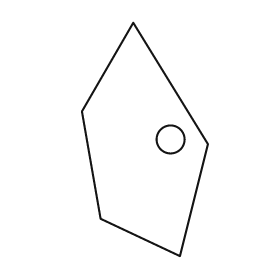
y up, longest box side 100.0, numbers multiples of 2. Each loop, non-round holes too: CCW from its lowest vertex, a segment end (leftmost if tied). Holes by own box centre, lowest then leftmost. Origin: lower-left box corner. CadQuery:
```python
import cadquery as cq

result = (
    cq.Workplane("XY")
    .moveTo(42.0, 0.0)
    .lineTo(54.0, 48.0)
    .lineTo(22.0, 100.0)
    .lineTo(0.0, 62.0)
    .lineTo(8.0, 16.0)
    .close()
    .moveTo(38.0, 50.0)
    .circle(6.0)
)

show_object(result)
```